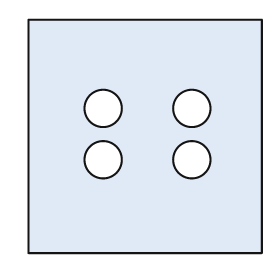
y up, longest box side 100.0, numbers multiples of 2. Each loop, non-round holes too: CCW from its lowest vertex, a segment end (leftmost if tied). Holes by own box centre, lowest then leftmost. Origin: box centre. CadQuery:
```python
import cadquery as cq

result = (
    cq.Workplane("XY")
    .moveTo(-50.0, -50.0)
    .lineTo(50.0, -50.0)
    .lineTo(50.0, 50.0)
    .lineTo(-50.0, 50.0)
    .close()
    .moveTo(-18.0, -10.0)
    .circle(8.0)
    .moveTo(20.0, -10.0)
    .circle(8.0)
    .moveTo(-18.0, 12.0)
    .circle(8.0)
    .moveTo(20.0, 12.0)
    .circle(8.0)
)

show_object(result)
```